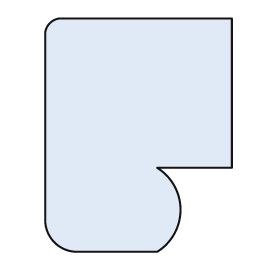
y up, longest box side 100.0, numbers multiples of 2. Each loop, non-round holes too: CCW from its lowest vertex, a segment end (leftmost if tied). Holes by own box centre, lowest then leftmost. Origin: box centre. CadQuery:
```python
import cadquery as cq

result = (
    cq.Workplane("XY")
    .moveTo(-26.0, -50.0)
    .lineTo(8.0, -50.0)
    .threePointArc((18.0, -32.0), (8.0, -14.0))
    .lineTo(40.0, -14.0)
    .lineTo(40.0, 50.0)
    .lineTo(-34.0, 50.0)
    .threePointArc((-38.0, 48.0), (-40.0, 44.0))
    .lineTo(-40.0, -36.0)
    .threePointArc((-36.0, -46.0), (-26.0, -50.0))
    .close()
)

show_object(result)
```